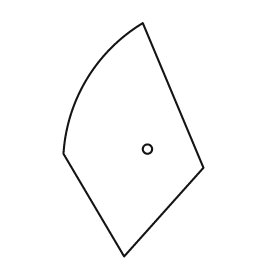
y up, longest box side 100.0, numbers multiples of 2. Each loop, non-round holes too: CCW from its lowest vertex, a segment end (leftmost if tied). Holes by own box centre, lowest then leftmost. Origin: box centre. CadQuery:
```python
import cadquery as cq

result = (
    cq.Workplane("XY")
    .moveTo(-4.0, -50.0)
    .lineTo(30.0, -12.0)
    .lineTo(4.0, 50.0)
    .threePointArc((-20.0, 26.0), (-30.0, -6.0))
    .close()
    .moveTo(6.0, -4.0)
    .circle(2.0)
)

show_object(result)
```